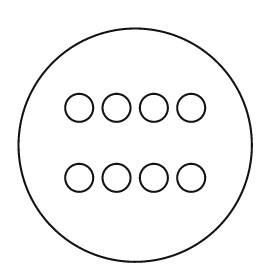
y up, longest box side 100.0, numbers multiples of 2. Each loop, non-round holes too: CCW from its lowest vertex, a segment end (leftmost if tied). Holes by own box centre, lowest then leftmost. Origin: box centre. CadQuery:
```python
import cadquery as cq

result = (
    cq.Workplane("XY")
    .moveTo(0.0, 0.0)
    .circle(50.0)
    .moveTo(-24.0, -14.0)
    .circle(6.0)
    .moveTo(-8.0, -14.0)
    .circle(6.0)
    .moveTo(8.0, -14.0)
    .circle(6.0)
    .moveTo(24.0, -14.0)
    .circle(6.0)
    .moveTo(-24.0, 16.0)
    .circle(6.0)
    .moveTo(-8.0, 16.0)
    .circle(6.0)
    .moveTo(8.0, 16.0)
    .circle(6.0)
    .moveTo(24.0, 16.0)
    .circle(6.0)
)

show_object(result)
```